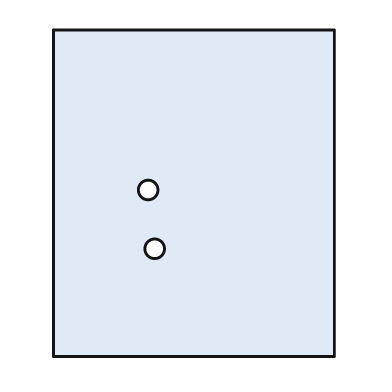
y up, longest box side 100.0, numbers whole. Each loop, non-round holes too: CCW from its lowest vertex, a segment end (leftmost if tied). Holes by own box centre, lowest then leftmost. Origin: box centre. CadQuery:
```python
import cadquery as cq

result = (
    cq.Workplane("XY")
    .moveTo(-43.0, -50.0)
    .lineTo(43.0, -50.0)
    .lineTo(43.0, 50.0)
    .lineTo(-43.0, 50.0)
    .close()
    .moveTo(-12.0, -17.0)
    .circle(3.0)
    .moveTo(-14.0, 1.0)
    .circle(3.0)
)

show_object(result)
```